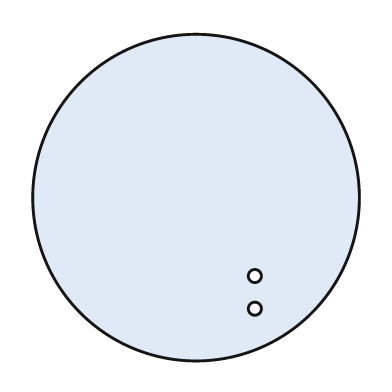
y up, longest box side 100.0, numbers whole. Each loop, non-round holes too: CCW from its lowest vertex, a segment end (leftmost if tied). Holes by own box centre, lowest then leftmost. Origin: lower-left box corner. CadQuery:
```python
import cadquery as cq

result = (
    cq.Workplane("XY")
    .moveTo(50.0, 50.0)
    .circle(50.0)
    .moveTo(68.0, 16.0)
    .circle(2.0)
    .moveTo(68.0, 26.0)
    .circle(2.0)
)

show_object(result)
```